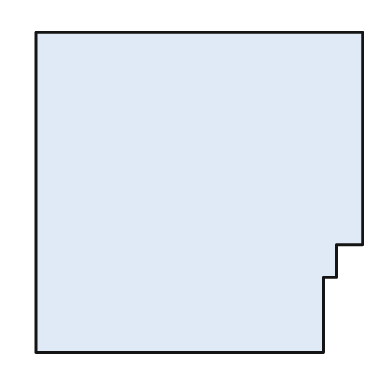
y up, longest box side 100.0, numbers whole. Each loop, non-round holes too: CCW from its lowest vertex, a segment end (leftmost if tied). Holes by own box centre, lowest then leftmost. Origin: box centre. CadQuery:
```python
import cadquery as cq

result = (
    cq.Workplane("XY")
    .moveTo(-50.0, -49.0)
    .lineTo(38.0, -49.0)
    .lineTo(38.0, -26.0)
    .lineTo(42.0, -26.0)
    .lineTo(42.0, -16.0)
    .lineTo(50.0, -16.0)
    .lineTo(50.0, 49.0)
    .lineTo(-50.0, 49.0)
    .close()
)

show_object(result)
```